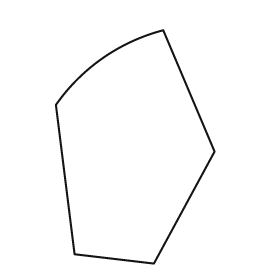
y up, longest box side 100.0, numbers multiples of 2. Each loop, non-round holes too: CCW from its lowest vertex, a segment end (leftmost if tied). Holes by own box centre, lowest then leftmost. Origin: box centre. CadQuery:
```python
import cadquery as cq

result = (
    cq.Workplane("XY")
    .moveTo(8.0, -50.0)
    .lineTo(34.0, -2.0)
    .lineTo(12.0, 50.0)
    .threePointArc((-14.0, 38.0), (-34.0, 18.0))
    .lineTo(-26.0, -46.0)
    .close()
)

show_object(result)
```